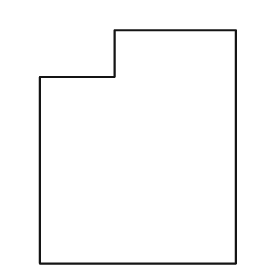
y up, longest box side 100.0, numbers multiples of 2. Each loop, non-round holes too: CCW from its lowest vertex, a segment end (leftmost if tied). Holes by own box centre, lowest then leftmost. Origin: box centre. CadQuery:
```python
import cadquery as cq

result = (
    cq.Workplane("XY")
    .moveTo(-42.0, -50.0)
    .lineTo(42.0, -50.0)
    .lineTo(42.0, 50.0)
    .lineTo(-10.0, 50.0)
    .lineTo(-10.0, 30.0)
    .lineTo(-42.0, 30.0)
    .close()
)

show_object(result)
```